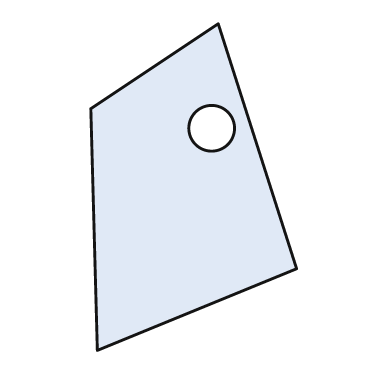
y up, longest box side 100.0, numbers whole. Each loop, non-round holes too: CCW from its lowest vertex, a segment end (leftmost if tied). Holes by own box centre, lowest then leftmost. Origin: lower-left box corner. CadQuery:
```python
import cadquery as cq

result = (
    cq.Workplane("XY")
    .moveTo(2.0, 0.0)
    .lineTo(63.0, 25.0)
    .lineTo(39.0, 100.0)
    .lineTo(0.0, 74.0)
    .close()
    .moveTo(37.0, 68.0)
    .circle(7.0)
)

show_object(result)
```